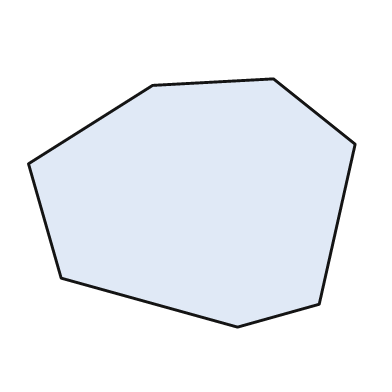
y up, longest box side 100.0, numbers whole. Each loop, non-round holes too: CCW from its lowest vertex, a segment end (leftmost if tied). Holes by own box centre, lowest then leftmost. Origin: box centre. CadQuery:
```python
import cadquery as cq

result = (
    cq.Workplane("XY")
    .moveTo(14.0, -38.0)
    .lineTo(39.0, -31.0)
    .lineTo(50.0, 18.0)
    .lineTo(25.0, 38.0)
    .lineTo(-12.0, 36.0)
    .lineTo(-50.0, 12.0)
    .lineTo(-40.0, -23.0)
    .close()
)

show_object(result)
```